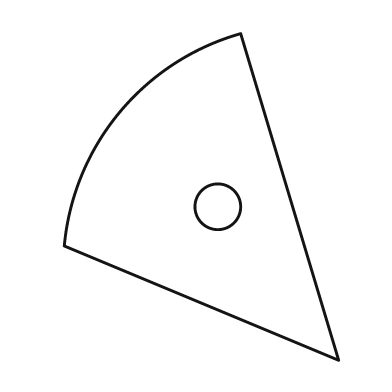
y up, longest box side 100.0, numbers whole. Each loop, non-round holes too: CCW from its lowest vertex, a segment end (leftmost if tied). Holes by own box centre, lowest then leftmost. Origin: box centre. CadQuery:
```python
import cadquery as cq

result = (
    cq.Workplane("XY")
    .moveTo(42.0, -50.0)
    .lineTo(12.0, 50.0)
    .threePointArc((-25.0, 26.0), (-42.0, -15.0))
    .close()
    .moveTo(5.0, -3.0)
    .circle(7.0)
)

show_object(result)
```